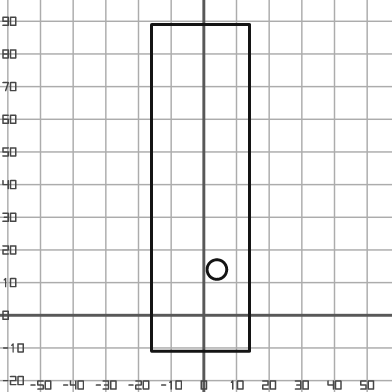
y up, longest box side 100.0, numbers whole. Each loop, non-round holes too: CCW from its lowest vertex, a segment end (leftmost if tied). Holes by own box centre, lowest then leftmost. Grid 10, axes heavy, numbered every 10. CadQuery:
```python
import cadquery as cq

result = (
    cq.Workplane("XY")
    .moveTo(-16.0, -11.0)
    .lineTo(14.0, -11.0)
    .lineTo(14.0, 89.0)
    .lineTo(-16.0, 89.0)
    .close()
    .moveTo(4.0, 14.0)
    .circle(3.0)
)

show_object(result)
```